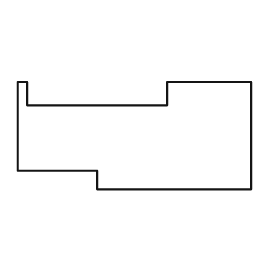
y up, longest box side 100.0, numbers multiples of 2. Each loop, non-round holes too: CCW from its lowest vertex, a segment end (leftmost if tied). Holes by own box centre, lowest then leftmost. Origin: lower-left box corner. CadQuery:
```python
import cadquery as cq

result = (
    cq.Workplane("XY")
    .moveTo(34.0, 0.0)
    .lineTo(100.0, 0.0)
    .lineTo(100.0, 46.0)
    .lineTo(64.0, 46.0)
    .lineTo(64.0, 36.0)
    .lineTo(4.0, 36.0)
    .lineTo(4.0, 46.0)
    .lineTo(0.0, 46.0)
    .lineTo(0.0, 8.0)
    .lineTo(34.0, 8.0)
    .close()
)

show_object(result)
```